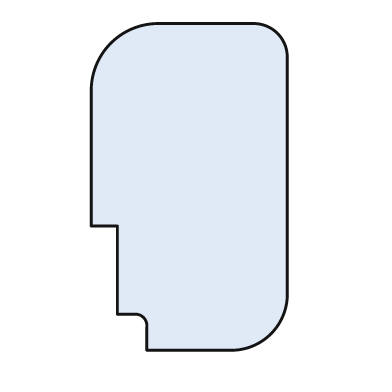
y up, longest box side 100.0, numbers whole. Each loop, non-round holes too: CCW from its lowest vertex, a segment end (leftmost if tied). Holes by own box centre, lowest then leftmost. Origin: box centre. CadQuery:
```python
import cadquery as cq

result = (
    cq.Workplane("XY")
    .moveTo(-13.0, -50.0)
    .lineTo(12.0, -50.0)
    .threePointArc((25.0, -45.0), (30.0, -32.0))
    .lineTo(30.0, 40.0)
    .threePointArc((27.0, 47.0), (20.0, 50.0))
    .lineTo(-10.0, 50.0)
    .threePointArc((-24.0, 44.0), (-30.0, 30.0))
    .lineTo(-30.0, -12.0)
    .lineTo(-22.0, -12.0)
    .lineTo(-22.0, -39.0)
    .lineTo(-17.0, -39.0)
    .threePointArc((-14.0, -40.0), (-13.0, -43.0))
    .close()
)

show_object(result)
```